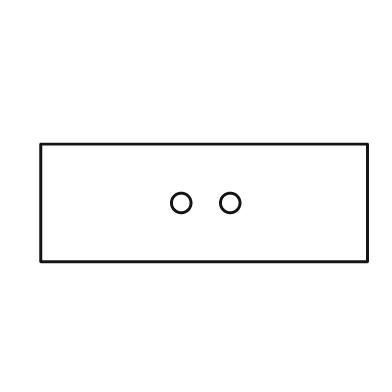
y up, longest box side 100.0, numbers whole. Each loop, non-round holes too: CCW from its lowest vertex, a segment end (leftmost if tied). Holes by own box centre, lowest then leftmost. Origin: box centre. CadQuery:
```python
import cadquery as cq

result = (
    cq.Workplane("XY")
    .moveTo(-50.0, -18.0)
    .lineTo(50.0, -18.0)
    .lineTo(50.0, 18.0)
    .lineTo(-50.0, 18.0)
    .close()
    .moveTo(-7.0, 0.0)
    .circle(3.0)
    .moveTo(8.0, 0.0)
    .circle(3.0)
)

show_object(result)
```